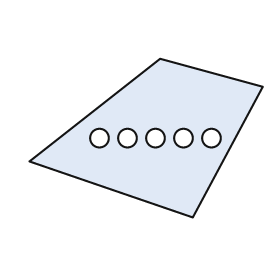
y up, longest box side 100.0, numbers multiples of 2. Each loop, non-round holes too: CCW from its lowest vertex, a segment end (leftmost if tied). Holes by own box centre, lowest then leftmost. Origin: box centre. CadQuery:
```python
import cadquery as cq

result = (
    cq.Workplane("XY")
    .moveTo(20.0, -34.0)
    .lineTo(50.0, 22.0)
    .lineTo(6.0, 34.0)
    .lineTo(-50.0, -10.0)
    .close()
    .moveTo(-20.0, 0.0)
    .circle(4.0)
    .moveTo(-8.0, 0.0)
    .circle(4.0)
    .moveTo(4.0, 0.0)
    .circle(4.0)
    .moveTo(16.0, 0.0)
    .circle(4.0)
    .moveTo(28.0, 0.0)
    .circle(4.0)
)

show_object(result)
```